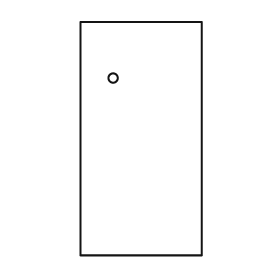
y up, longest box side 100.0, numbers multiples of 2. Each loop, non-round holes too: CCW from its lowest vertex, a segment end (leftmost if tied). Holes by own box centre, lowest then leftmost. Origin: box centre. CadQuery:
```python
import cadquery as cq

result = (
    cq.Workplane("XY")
    .moveTo(-26.0, -50.0)
    .lineTo(26.0, -50.0)
    .lineTo(26.0, 50.0)
    .lineTo(-26.0, 50.0)
    .close()
    .moveTo(-12.0, 26.0)
    .circle(2.0)
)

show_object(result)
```